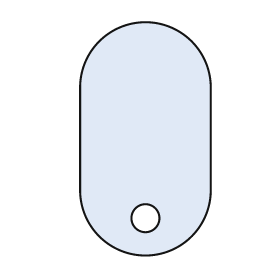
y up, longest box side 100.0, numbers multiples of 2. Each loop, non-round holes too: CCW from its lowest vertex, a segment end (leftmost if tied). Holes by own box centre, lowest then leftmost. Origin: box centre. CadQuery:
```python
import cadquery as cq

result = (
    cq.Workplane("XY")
    .moveTo(-28.0, -22.0)
    .threePointArc((0.0, -50.0), (28.0, -22.0))
    .lineTo(28.0, 22.0)
    .threePointArc((0.0, 50.0), (-28.0, 22.0))
    .close()
    .moveTo(0.0, -34.0)
    .circle(6.0)
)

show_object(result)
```